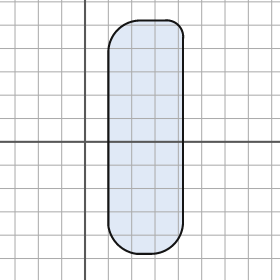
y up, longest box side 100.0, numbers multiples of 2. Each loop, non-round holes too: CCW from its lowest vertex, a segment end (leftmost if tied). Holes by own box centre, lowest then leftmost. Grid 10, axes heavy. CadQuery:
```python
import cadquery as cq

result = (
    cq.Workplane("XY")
    .moveTo(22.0, -48.0)
    .lineTo(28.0, -48.0)
    .threePointArc((38.0, -44.0), (42.0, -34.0))
    .lineTo(42.0, 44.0)
    .threePointArc((40.0, 50.0), (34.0, 52.0))
    .lineTo(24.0, 52.0)
    .threePointArc((14.0, 48.0), (10.0, 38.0))
    .lineTo(10.0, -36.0)
    .threePointArc((14.0, -44.0), (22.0, -48.0))
    .close()
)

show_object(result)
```